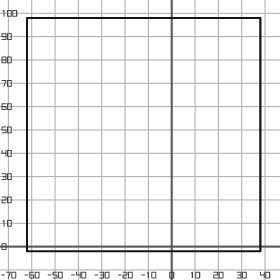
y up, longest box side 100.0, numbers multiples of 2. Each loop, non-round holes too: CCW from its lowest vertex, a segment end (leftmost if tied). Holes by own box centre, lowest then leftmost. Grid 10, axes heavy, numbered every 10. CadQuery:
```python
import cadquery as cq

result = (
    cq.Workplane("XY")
    .moveTo(-62.0, -2.0)
    .lineTo(38.0, -2.0)
    .lineTo(38.0, 98.0)
    .lineTo(-62.0, 98.0)
    .close()
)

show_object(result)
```